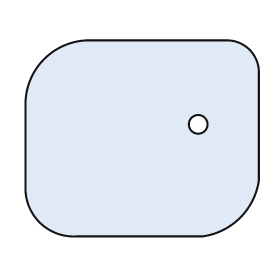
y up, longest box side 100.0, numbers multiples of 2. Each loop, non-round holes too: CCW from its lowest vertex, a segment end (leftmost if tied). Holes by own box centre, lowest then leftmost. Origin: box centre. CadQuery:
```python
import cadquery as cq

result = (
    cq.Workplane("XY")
    .moveTo(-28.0, -42.0)
    .lineTo(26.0, -42.0)
    .threePointArc((42.0, -34.0), (50.0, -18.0))
    .lineTo(50.0, 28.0)
    .threePointArc((46.0, 38.0), (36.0, 42.0))
    .lineTo(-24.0, 42.0)
    .threePointArc((-42.0, 34.0), (-50.0, 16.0))
    .lineTo(-50.0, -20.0)
    .threePointArc((-44.0, -36.0), (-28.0, -42.0))
    .close()
    .moveTo(24.0, 6.0)
    .circle(4.0)
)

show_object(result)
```